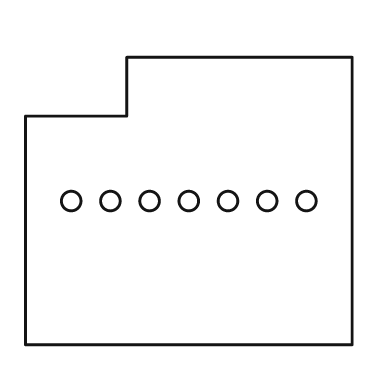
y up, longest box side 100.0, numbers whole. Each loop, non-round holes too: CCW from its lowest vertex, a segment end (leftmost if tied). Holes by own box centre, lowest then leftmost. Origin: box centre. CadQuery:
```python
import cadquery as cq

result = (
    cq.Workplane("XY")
    .moveTo(-50.0, -44.0)
    .lineTo(50.0, -44.0)
    .lineTo(50.0, 44.0)
    .lineTo(-19.0, 44.0)
    .lineTo(-19.0, 26.0)
    .lineTo(-50.0, 26.0)
    .close()
    .moveTo(-36.0, 0.0)
    .circle(3.0)
    .moveTo(-24.0, 0.0)
    .circle(3.0)
    .moveTo(-12.0, 0.0)
    .circle(3.0)
    .moveTo(0.0, 0.0)
    .circle(3.0)
    .moveTo(12.0, 0.0)
    .circle(3.0)
    .moveTo(24.0, 0.0)
    .circle(3.0)
    .moveTo(36.0, 0.0)
    .circle(3.0)
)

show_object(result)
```